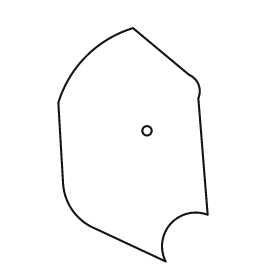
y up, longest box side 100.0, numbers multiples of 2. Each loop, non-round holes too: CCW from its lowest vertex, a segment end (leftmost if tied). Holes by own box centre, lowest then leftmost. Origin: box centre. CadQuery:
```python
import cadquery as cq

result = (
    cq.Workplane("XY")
    .moveTo(14.0, -50.0)
    .threePointArc((16.0, -34.0), (32.0, -30.0))
    .lineTo(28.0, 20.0)
    .threePointArc((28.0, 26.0), (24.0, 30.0))
    .lineTo(0.0, 50.0)
    .threePointArc((-20.0, 38.0), (-32.0, 18.0))
    .lineTo(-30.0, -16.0)
    .threePointArc((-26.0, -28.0), (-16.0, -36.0))
    .close()
    .moveTo(6.0, 6.0)
    .circle(2.0)
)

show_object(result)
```